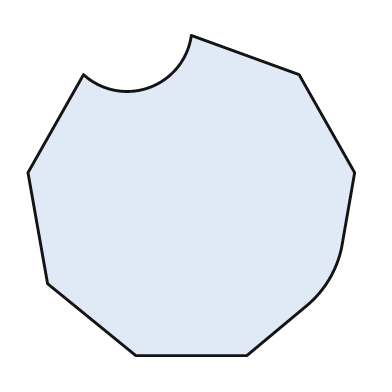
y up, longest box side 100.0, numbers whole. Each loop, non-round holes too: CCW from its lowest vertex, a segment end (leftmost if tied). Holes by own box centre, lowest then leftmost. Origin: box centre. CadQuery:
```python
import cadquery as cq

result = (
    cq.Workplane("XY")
    .moveTo(-17.0, -49.0)
    .lineTo(17.0, -49.0)
    .lineTo(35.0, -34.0)
    .threePointArc((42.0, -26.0), (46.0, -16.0))
    .lineTo(50.0, 7.0)
    .lineTo(33.0, 37.0)
    .lineTo(0.0, 49.0)
    .threePointArc((-13.0, 33.0), (-33.0, 37.0))
    .lineTo(-50.0, 7.0)
    .lineTo(-44.0, -27.0)
    .close()
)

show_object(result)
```